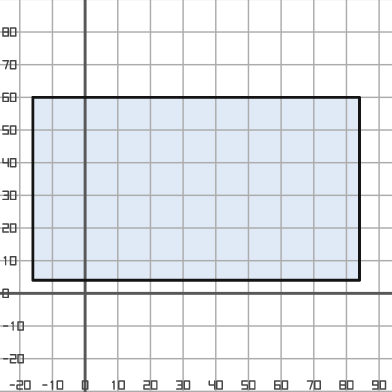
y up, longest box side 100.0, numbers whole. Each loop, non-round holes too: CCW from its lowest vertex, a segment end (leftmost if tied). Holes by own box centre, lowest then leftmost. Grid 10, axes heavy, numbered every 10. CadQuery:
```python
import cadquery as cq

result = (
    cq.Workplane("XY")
    .moveTo(-16.0, 4.0)
    .lineTo(84.0, 4.0)
    .lineTo(84.0, 60.0)
    .lineTo(-16.0, 60.0)
    .close()
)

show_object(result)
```